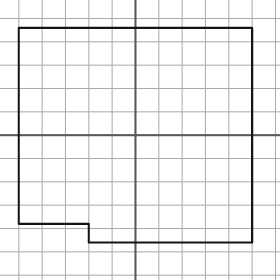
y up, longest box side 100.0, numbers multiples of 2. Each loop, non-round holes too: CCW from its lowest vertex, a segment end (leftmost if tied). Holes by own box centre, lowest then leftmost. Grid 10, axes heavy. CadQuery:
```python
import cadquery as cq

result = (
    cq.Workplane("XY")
    .moveTo(-20.0, -46.0)
    .lineTo(50.0, -46.0)
    .lineTo(50.0, 46.0)
    .lineTo(-50.0, 46.0)
    .lineTo(-50.0, -38.0)
    .lineTo(-20.0, -38.0)
    .close()
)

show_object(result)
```